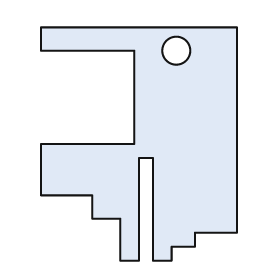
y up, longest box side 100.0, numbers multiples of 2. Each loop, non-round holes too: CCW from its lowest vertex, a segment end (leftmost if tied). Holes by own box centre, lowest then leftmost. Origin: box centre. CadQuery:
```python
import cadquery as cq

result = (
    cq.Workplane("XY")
    .moveTo(-8.0, -50.0)
    .lineTo(0.0, -50.0)
    .lineTo(0.0, -6.0)
    .lineTo(6.0, -6.0)
    .lineTo(6.0, -50.0)
    .lineTo(14.0, -50.0)
    .lineTo(14.0, -44.0)
    .lineTo(24.0, -44.0)
    .lineTo(24.0, -38.0)
    .lineTo(42.0, -38.0)
    .lineTo(42.0, 50.0)
    .lineTo(-42.0, 50.0)
    .lineTo(-42.0, 40.0)
    .lineTo(-2.0, 40.0)
    .lineTo(-2.0, 0.0)
    .lineTo(-42.0, 0.0)
    .lineTo(-42.0, -22.0)
    .lineTo(-20.0, -22.0)
    .lineTo(-20.0, -32.0)
    .lineTo(-8.0, -32.0)
    .close()
    .moveTo(16.0, 40.0)
    .circle(6.0)
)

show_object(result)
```